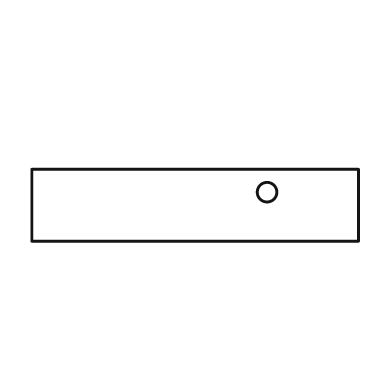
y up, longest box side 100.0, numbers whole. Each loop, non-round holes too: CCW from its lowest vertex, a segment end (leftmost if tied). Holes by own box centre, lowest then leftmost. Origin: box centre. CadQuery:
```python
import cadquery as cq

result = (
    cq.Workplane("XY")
    .moveTo(-50.0, -11.0)
    .lineTo(50.0, -11.0)
    .lineTo(50.0, 11.0)
    .lineTo(-50.0, 11.0)
    .close()
    .moveTo(22.0, 4.0)
    .circle(3.0)
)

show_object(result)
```